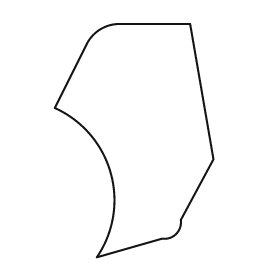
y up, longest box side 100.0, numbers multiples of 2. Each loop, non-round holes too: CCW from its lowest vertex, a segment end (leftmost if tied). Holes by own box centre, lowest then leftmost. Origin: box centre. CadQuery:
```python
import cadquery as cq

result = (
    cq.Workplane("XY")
    .moveTo(-16.0, -50.0)
    .lineTo(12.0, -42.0)
    .threePointArc((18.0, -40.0), (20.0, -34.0))
    .lineTo(34.0, -8.0)
    .lineTo(24.0, 50.0)
    .lineTo(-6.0, 50.0)
    .threePointArc((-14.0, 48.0), (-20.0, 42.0))
    .lineTo(-34.0, 14.0)
    .threePointArc((-10.0, -14.0), (-16.0, -50.0))
    .close()
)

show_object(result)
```